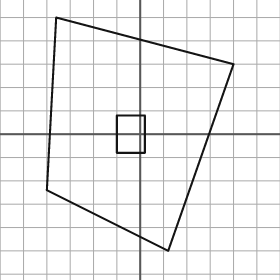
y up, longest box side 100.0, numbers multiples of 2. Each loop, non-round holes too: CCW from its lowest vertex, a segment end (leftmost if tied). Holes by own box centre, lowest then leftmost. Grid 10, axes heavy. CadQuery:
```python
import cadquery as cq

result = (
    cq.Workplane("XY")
    .moveTo(12.0, -50.0)
    .lineTo(40.0, 30.0)
    .lineTo(-36.0, 50.0)
    .lineTo(-40.0, -24.0)
    .close()
    .moveTo(-10.0, -8.0)
    .lineTo(2.0, -8.0)
    .lineTo(2.0, 8.0)
    .lineTo(-10.0, 8.0)
    .close()
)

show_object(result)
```